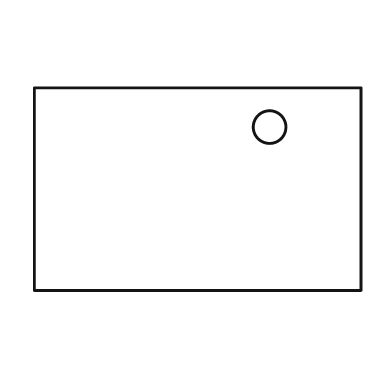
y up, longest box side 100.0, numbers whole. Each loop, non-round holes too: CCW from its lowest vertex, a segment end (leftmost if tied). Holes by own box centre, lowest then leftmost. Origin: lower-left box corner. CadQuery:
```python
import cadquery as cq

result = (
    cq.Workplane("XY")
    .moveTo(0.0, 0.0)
    .lineTo(100.0, 0.0)
    .lineTo(100.0, 62.0)
    .lineTo(0.0, 62.0)
    .close()
    .moveTo(72.0, 50.0)
    .circle(5.0)
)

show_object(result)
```